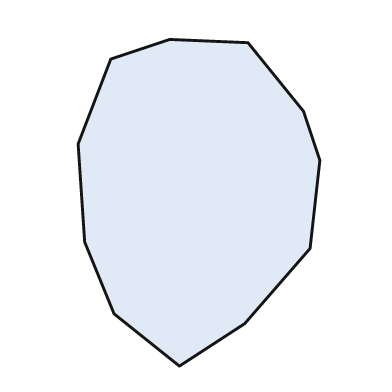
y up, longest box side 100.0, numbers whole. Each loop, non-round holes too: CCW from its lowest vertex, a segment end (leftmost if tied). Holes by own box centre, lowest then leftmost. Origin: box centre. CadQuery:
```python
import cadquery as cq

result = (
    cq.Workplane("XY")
    .moveTo(-6.0, -50.0)
    .lineTo(14.0, -37.0)
    .lineTo(34.0, -14.0)
    .lineTo(37.0, 13.0)
    .lineTo(32.0, 28.0)
    .lineTo(15.0, 49.0)
    .lineTo(-9.0, 50.0)
    .lineTo(-27.0, 44.0)
    .lineTo(-37.0, 18.0)
    .lineTo(-35.0, -12.0)
    .lineTo(-26.0, -34.0)
    .close()
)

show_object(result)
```